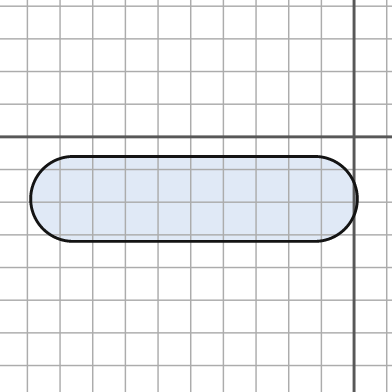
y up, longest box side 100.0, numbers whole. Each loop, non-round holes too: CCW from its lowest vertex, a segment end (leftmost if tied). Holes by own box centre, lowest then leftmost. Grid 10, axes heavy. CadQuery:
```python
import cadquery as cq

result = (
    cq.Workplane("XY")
    .moveTo(-86.0, -32.0)
    .lineTo(-12.0, -32.0)
    .threePointArc((1.0, -19.0), (-12.0, -6.0))
    .lineTo(-86.0, -6.0)
    .threePointArc((-99.0, -19.0), (-86.0, -32.0))
    .close()
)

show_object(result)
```